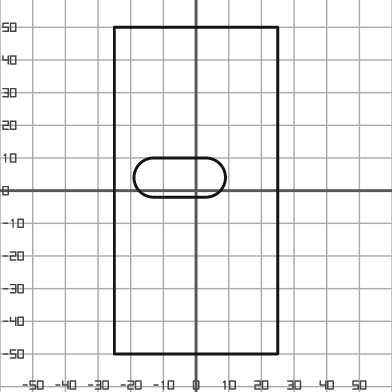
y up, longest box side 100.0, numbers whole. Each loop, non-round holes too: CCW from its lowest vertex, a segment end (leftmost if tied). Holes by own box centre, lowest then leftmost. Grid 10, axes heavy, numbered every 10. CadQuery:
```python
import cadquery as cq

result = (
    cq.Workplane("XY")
    .moveTo(-25.0, -50.0)
    .lineTo(25.0, -50.0)
    .lineTo(25.0, 50.0)
    .lineTo(-25.0, 50.0)
    .close()
    .moveTo(-13.0, -2.0)
    .lineTo(3.0, -2.0)
    .threePointArc((9.0, 4.0), (3.0, 10.0))
    .lineTo(-13.0, 10.0)
    .threePointArc((-19.0, 4.0), (-13.0, -2.0))
    .close()
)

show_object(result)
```